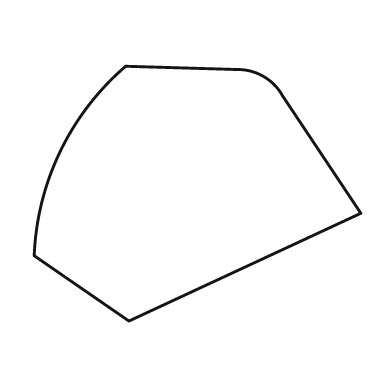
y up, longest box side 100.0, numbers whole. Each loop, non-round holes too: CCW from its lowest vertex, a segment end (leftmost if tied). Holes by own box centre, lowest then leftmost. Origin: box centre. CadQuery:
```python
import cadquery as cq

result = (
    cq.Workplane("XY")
    .moveTo(-21.0, -39.0)
    .lineTo(50.0, -6.0)
    .lineTo(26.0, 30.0)
    .threePointArc((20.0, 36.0), (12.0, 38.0))
    .lineTo(-22.0, 39.0)
    .threePointArc((-42.0, 13.0), (-50.0, -19.0))
    .close()
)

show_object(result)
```